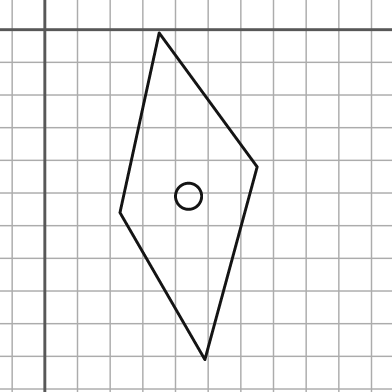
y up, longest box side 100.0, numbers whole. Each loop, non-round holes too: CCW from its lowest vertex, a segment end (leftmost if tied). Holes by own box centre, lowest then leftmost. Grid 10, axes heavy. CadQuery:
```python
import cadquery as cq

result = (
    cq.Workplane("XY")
    .moveTo(49.0, -101.0)
    .lineTo(65.0, -42.0)
    .lineTo(35.0, -1.0)
    .lineTo(23.0, -56.0)
    .close()
    .moveTo(44.0, -51.0)
    .circle(4.0)
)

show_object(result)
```